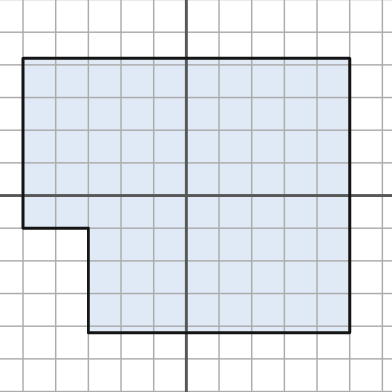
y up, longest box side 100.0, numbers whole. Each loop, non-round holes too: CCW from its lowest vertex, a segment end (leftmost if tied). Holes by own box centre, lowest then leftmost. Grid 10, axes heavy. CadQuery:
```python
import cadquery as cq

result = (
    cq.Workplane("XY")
    .moveTo(-30.0, -42.0)
    .lineTo(50.0, -42.0)
    .lineTo(50.0, 42.0)
    .lineTo(-50.0, 42.0)
    .lineTo(-50.0, -10.0)
    .lineTo(-30.0, -10.0)
    .close()
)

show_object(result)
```